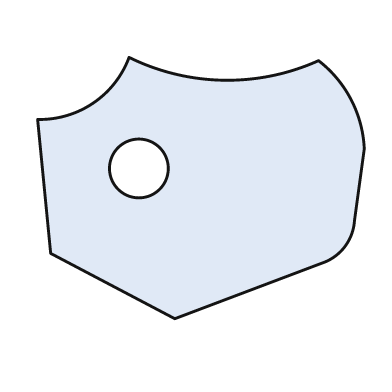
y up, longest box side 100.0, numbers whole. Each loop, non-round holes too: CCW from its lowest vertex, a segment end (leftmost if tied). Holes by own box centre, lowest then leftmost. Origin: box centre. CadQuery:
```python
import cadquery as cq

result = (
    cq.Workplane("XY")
    .moveTo(-8.0, -40.0)
    .lineTo(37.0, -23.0)
    .threePointArc((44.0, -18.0), (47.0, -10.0))
    .lineTo(50.0, 12.0)
    .threePointArc((46.0, 27.0), (36.0, 39.0))
    .threePointArc((7.0, 33.0), (-22.0, 40.0))
    .threePointArc((-33.0, 26.0), (-50.0, 21.0))
    .lineTo(-46.0, -20.0)
    .close()
    .moveTo(-19.0, 6.0)
    .circle(9.0)
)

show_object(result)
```